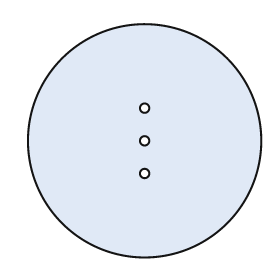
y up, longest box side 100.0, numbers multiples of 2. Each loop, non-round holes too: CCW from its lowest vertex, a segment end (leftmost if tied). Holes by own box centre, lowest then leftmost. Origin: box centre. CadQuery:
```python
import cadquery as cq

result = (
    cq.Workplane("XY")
    .moveTo(0.0, 0.0)
    .circle(50.0)
    .moveTo(0.0, -14.0)
    .circle(2.0)
    .moveTo(0.0, 0.0)
    .circle(2.0)
    .moveTo(0.0, 14.0)
    .circle(2.0)
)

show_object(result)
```